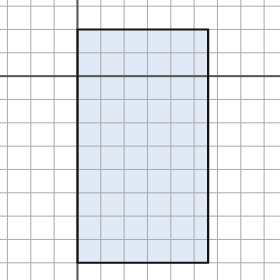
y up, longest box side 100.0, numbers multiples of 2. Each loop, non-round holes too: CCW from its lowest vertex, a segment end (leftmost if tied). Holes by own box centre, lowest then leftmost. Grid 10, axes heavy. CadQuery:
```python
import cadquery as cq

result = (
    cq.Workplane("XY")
    .moveTo(0.0, -80.0)
    .lineTo(56.0, -80.0)
    .lineTo(56.0, 20.0)
    .lineTo(0.0, 20.0)
    .close()
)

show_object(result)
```